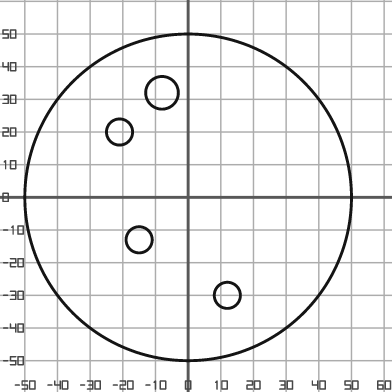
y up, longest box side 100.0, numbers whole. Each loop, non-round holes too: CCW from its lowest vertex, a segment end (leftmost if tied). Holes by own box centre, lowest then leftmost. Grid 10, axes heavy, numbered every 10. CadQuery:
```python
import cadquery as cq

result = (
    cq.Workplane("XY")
    .moveTo(0.0, 0.0)
    .circle(50.0)
    .moveTo(12.0, -30.0)
    .circle(4.0)
    .moveTo(-15.0, -13.0)
    .circle(4.0)
    .moveTo(-21.0, 20.0)
    .circle(4.0)
    .moveTo(-8.0, 32.0)
    .circle(5.0)
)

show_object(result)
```